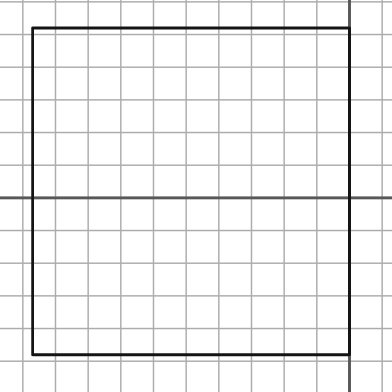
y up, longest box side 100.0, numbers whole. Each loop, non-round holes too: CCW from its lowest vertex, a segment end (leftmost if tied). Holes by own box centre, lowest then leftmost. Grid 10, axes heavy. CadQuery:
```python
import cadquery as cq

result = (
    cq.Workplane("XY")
    .moveTo(-97.0, -48.0)
    .lineTo(0.0, -48.0)
    .lineTo(0.0, 52.0)
    .lineTo(-97.0, 52.0)
    .close()
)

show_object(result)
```